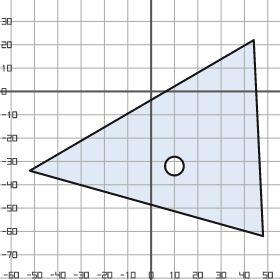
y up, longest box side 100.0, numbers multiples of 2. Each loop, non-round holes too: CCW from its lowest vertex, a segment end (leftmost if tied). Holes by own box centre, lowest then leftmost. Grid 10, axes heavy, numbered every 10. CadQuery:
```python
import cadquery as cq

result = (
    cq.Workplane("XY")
    .moveTo(48.0, -62.0)
    .lineTo(44.0, 22.0)
    .lineTo(-52.0, -34.0)
    .close()
    .moveTo(10.0, -32.0)
    .circle(4.0)
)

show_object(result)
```